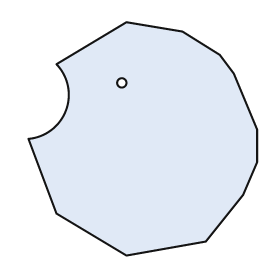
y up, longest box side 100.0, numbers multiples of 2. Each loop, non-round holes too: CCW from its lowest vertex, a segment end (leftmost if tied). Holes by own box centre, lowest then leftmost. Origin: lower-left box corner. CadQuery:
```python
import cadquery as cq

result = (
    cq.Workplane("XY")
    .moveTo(42.0, 0.0)
    .lineTo(76.0, 6.0)
    .lineTo(92.0, 26.0)
    .lineTo(98.0, 40.0)
    .lineTo(98.0, 54.0)
    .lineTo(88.0, 78.0)
    .lineTo(82.0, 86.0)
    .lineTo(66.0, 96.0)
    .lineTo(42.0, 100.0)
    .lineTo(12.0, 82.0)
    .threePointArc((16.0, 62.0), (0.0, 50.0))
    .lineTo(12.0, 18.0)
    .close()
    .moveTo(40.0, 74.0)
    .circle(2.0)
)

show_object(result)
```